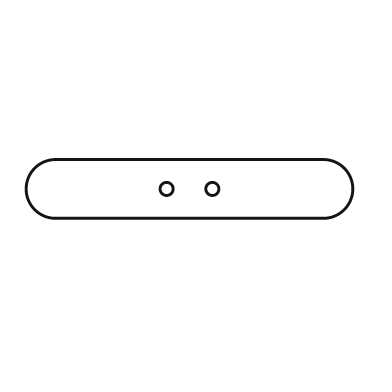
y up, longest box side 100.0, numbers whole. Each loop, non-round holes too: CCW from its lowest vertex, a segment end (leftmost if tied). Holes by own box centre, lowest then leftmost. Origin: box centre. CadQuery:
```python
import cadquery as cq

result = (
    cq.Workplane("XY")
    .moveTo(-41.0, -9.0)
    .lineTo(41.0, -9.0)
    .threePointArc((50.0, 0.0), (41.0, 9.0))
    .lineTo(-41.0, 9.0)
    .threePointArc((-50.0, 0.0), (-41.0, -9.0))
    .close()
    .moveTo(-7.0, 0.0)
    .circle(2.0)
    .moveTo(7.0, 0.0)
    .circle(2.0)
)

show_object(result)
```